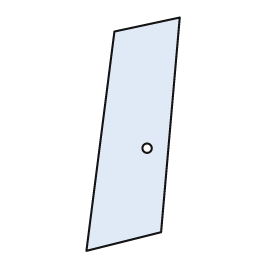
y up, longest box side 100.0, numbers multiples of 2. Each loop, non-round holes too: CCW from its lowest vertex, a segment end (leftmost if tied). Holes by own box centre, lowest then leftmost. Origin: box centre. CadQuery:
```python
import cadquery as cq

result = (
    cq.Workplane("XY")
    .moveTo(-20.0, -50.0)
    .lineTo(12.0, -42.0)
    .lineTo(20.0, 50.0)
    .lineTo(-8.0, 44.0)
    .close()
    .moveTo(6.0, -6.0)
    .circle(2.0)
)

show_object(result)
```